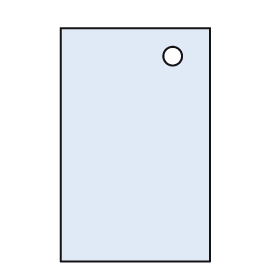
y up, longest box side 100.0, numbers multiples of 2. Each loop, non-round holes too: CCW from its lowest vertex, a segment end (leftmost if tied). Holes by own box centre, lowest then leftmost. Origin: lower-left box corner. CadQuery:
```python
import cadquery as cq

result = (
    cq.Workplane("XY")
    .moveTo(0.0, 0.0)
    .lineTo(64.0, 0.0)
    .lineTo(64.0, 100.0)
    .lineTo(0.0, 100.0)
    .close()
    .moveTo(48.0, 88.0)
    .circle(4.0)
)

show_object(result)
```